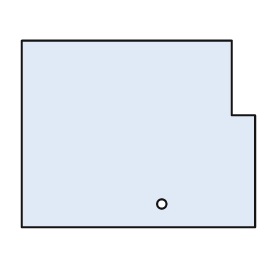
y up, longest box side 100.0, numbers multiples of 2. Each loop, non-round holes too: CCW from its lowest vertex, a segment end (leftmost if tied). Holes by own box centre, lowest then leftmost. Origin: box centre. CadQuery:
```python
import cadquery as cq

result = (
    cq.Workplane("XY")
    .moveTo(-50.0, -40.0)
    .lineTo(50.0, -40.0)
    .lineTo(50.0, 8.0)
    .lineTo(40.0, 8.0)
    .lineTo(40.0, 40.0)
    .lineTo(-50.0, 40.0)
    .close()
    .moveTo(10.0, -30.0)
    .circle(2.0)
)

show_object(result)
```